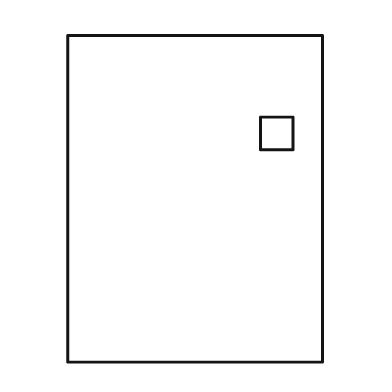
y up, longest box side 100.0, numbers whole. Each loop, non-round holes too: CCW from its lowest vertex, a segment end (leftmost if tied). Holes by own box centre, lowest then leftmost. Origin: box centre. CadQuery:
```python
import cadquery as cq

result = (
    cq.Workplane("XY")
    .moveTo(-39.0, -50.0)
    .lineTo(39.0, -50.0)
    .lineTo(39.0, 50.0)
    .lineTo(-39.0, 50.0)
    .close()
    .moveTo(20.0, 15.0)
    .lineTo(30.0, 15.0)
    .lineTo(30.0, 25.0)
    .lineTo(20.0, 25.0)
    .close()
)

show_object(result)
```